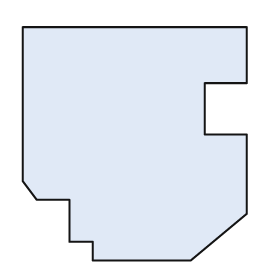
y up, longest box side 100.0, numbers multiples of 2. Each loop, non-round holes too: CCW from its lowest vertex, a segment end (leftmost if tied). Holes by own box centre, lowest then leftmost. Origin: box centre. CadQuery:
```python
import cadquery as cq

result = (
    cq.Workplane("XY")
    .moveTo(-18.0, -50.0)
    .lineTo(24.0, -50.0)
    .lineTo(48.0, -30.0)
    .lineTo(48.0, 4.0)
    .lineTo(30.0, 4.0)
    .lineTo(30.0, 26.0)
    .lineTo(48.0, 26.0)
    .lineTo(48.0, 50.0)
    .lineTo(-48.0, 50.0)
    .lineTo(-48.0, -16.0)
    .lineTo(-42.0, -24.0)
    .lineTo(-28.0, -24.0)
    .lineTo(-28.0, -42.0)
    .lineTo(-18.0, -42.0)
    .close()
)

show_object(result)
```